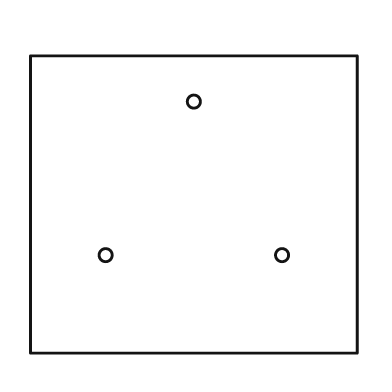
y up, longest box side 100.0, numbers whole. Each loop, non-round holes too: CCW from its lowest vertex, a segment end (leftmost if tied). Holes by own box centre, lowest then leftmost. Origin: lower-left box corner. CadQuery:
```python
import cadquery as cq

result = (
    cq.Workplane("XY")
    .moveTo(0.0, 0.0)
    .lineTo(100.0, 0.0)
    .lineTo(100.0, 91.0)
    .lineTo(0.0, 91.0)
    .close()
    .moveTo(23.0, 30.0)
    .circle(2.0)
    .moveTo(77.0, 30.0)
    .circle(2.0)
    .moveTo(50.0, 77.0)
    .circle(2.0)
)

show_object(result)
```